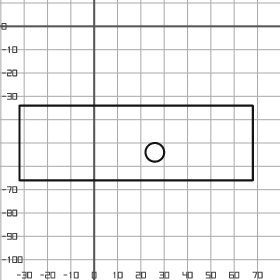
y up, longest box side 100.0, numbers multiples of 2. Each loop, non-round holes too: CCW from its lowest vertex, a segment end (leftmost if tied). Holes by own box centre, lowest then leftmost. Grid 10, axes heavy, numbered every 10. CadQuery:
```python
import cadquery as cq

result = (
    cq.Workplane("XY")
    .moveTo(-32.0, -66.0)
    .lineTo(68.0, -66.0)
    .lineTo(68.0, -34.0)
    .lineTo(-32.0, -34.0)
    .close()
    .moveTo(26.0, -54.0)
    .circle(4.0)
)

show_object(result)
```